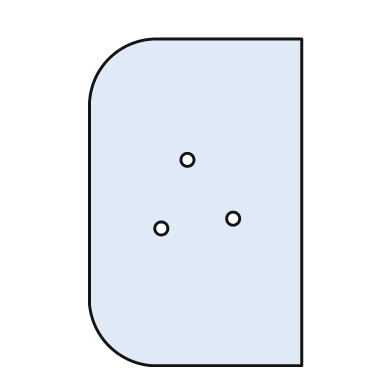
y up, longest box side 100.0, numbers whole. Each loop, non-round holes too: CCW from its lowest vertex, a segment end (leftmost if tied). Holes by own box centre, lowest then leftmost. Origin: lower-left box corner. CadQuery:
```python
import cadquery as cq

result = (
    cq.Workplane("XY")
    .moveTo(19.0, 0.0)
    .lineTo(65.0, 0.0)
    .lineTo(65.0, 100.0)
    .lineTo(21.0, 100.0)
    .threePointArc((6.0, 94.0), (0.0, 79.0))
    .lineTo(0.0, 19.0)
    .threePointArc((6.0, 6.0), (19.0, 0.0))
    .close()
    .moveTo(22.0, 42.0)
    .circle(2.0)
    .moveTo(44.0, 45.0)
    .circle(2.0)
    .moveTo(30.0, 63.0)
    .circle(2.0)
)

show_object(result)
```